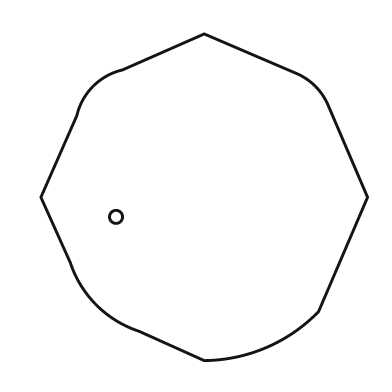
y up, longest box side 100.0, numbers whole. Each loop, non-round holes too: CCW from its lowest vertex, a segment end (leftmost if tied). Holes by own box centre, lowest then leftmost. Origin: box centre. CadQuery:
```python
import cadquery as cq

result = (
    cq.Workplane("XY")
    .moveTo(0.0, -50.0)
    .threePointArc((19.0, -46.0), (35.0, -35.0))
    .lineTo(50.0, 0.0)
    .lineTo(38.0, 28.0)
    .threePointArc((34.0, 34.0), (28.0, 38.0))
    .lineTo(0.0, 50.0)
    .lineTo(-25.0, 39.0)
    .threePointArc((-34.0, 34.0), (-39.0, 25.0))
    .lineTo(-50.0, 0.0)
    .lineTo(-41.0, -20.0)
    .threePointArc((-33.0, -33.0), (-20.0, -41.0))
    .close()
    .moveTo(-27.0, -6.0)
    .circle(2.0)
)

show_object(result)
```